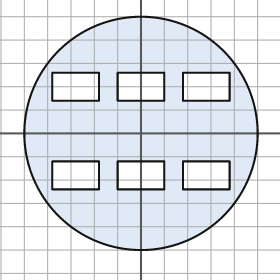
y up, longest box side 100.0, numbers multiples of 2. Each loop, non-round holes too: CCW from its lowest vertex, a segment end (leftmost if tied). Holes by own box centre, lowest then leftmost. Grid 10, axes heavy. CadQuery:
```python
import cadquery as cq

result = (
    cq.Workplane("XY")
    .moveTo(0.0, 0.0)
    .circle(50.0)
    .moveTo(-38.0, -24.0)
    .lineTo(-18.0, -24.0)
    .lineTo(-18.0, -12.0)
    .lineTo(-38.0, -12.0)
    .close()
    .moveTo(-10.0, -24.0)
    .lineTo(10.0, -24.0)
    .lineTo(10.0, -12.0)
    .lineTo(-10.0, -12.0)
    .close()
    .moveTo(18.0, -24.0)
    .lineTo(38.0, -24.0)
    .lineTo(38.0, -12.0)
    .lineTo(18.0, -12.0)
    .close()
    .moveTo(-38.0, 14.0)
    .lineTo(-18.0, 14.0)
    .lineTo(-18.0, 26.0)
    .lineTo(-38.0, 26.0)
    .close()
    .moveTo(-10.0, 14.0)
    .lineTo(10.0, 14.0)
    .lineTo(10.0, 26.0)
    .lineTo(-10.0, 26.0)
    .close()
    .moveTo(18.0, 14.0)
    .lineTo(38.0, 14.0)
    .lineTo(38.0, 26.0)
    .lineTo(18.0, 26.0)
    .close()
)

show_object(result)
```